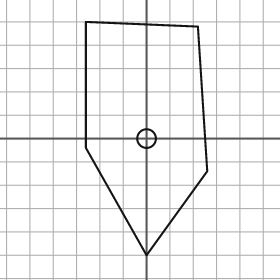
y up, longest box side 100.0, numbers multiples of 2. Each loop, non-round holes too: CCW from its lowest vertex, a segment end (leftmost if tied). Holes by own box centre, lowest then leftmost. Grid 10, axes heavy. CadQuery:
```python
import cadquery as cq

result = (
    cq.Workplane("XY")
    .moveTo(0.0, -50.0)
    .lineTo(26.0, -14.0)
    .lineTo(22.0, 48.0)
    .lineTo(-26.0, 50.0)
    .lineTo(-26.0, -4.0)
    .close()
    .moveTo(0.0, 0.0)
    .circle(4.0)
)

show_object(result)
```